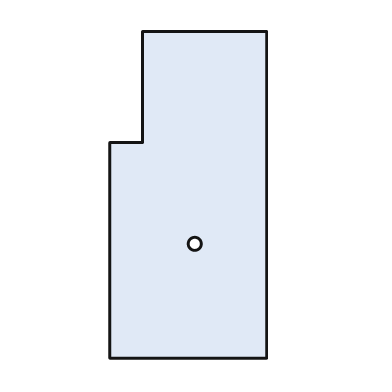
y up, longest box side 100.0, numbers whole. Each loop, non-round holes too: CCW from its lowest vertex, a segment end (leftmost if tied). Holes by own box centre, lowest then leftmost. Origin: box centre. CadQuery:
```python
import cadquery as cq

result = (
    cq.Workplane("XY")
    .moveTo(-24.0, -50.0)
    .lineTo(24.0, -50.0)
    .lineTo(24.0, 50.0)
    .lineTo(-14.0, 50.0)
    .lineTo(-14.0, 16.0)
    .lineTo(-24.0, 16.0)
    .close()
    .moveTo(2.0, -15.0)
    .circle(2.0)
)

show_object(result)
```